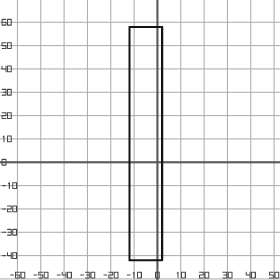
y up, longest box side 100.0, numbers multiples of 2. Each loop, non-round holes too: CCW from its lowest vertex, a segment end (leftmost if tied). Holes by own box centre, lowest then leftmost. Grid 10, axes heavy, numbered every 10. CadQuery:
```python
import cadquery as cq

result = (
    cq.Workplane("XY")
    .moveTo(-12.0, -42.0)
    .lineTo(2.0, -42.0)
    .lineTo(2.0, 58.0)
    .lineTo(-12.0, 58.0)
    .close()
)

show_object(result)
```